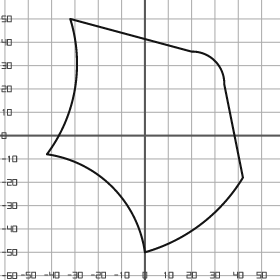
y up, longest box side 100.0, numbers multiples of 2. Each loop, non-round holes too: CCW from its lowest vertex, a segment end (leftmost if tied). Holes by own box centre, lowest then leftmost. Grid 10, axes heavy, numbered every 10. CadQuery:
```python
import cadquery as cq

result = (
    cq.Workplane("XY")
    .moveTo(0.0, -50.0)
    .threePointArc((24.0, -38.0), (42.0, -18.0))
    .lineTo(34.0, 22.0)
    .threePointArc((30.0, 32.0), (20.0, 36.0))
    .lineTo(-32.0, 50.0)
    .threePointArc((-30.0, 20.0), (-42.0, -8.0))
    .threePointArc((-14.0, -22.0), (0.0, -50.0))
    .close()
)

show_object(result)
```